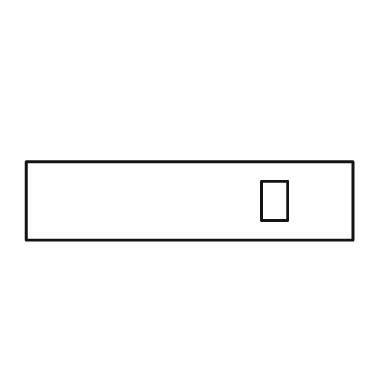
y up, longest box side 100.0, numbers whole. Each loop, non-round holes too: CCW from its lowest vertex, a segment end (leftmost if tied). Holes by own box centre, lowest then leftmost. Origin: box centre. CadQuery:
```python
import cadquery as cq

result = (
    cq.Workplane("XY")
    .moveTo(-50.0, -12.0)
    .lineTo(50.0, -12.0)
    .lineTo(50.0, 12.0)
    .lineTo(-50.0, 12.0)
    .close()
    .moveTo(22.0, -6.0)
    .lineTo(30.0, -6.0)
    .lineTo(30.0, 6.0)
    .lineTo(22.0, 6.0)
    .close()
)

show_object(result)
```